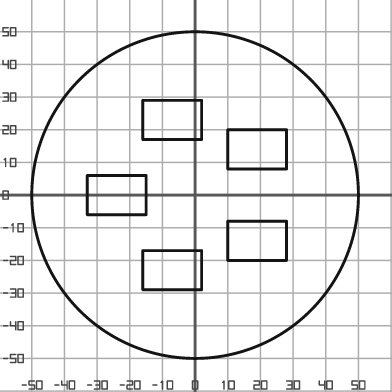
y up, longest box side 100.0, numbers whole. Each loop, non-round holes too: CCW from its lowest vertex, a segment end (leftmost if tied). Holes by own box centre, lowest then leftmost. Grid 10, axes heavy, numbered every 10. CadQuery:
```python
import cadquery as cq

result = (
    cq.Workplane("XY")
    .moveTo(0.0, 0.0)
    .circle(50.0)
    .moveTo(-16.0, -29.0)
    .lineTo(2.0, -29.0)
    .lineTo(2.0, -17.0)
    .lineTo(-16.0, -17.0)
    .close()
    .moveTo(10.0, -20.0)
    .lineTo(28.0, -20.0)
    .lineTo(28.0, -8.0)
    .lineTo(10.0, -8.0)
    .close()
    .moveTo(-33.0, -6.0)
    .lineTo(-15.0, -6.0)
    .lineTo(-15.0, 6.0)
    .lineTo(-33.0, 6.0)
    .close()
    .moveTo(10.0, 8.0)
    .lineTo(28.0, 8.0)
    .lineTo(28.0, 20.0)
    .lineTo(10.0, 20.0)
    .close()
    .moveTo(-16.0, 17.0)
    .lineTo(2.0, 17.0)
    .lineTo(2.0, 29.0)
    .lineTo(-16.0, 29.0)
    .close()
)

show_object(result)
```